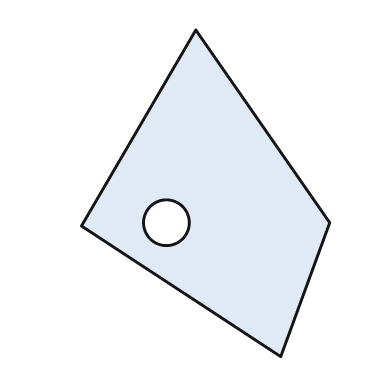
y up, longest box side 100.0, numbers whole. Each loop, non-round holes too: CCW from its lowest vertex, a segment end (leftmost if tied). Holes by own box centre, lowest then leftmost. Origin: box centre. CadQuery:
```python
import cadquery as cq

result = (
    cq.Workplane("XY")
    .moveTo(23.0, -50.0)
    .lineTo(38.0, -9.0)
    .lineTo(-3.0, 50.0)
    .lineTo(-38.0, -10.0)
    .close()
    .moveTo(-12.0, -9.0)
    .circle(7.0)
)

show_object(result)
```